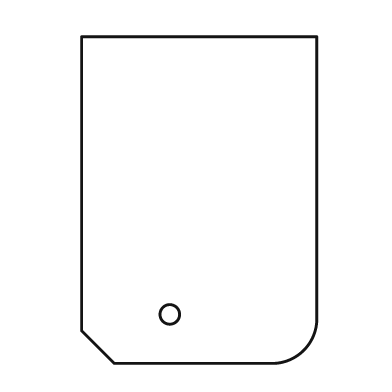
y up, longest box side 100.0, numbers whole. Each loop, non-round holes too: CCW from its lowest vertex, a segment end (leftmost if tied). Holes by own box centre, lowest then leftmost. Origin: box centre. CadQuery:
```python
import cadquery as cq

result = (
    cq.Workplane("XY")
    .moveTo(-26.0, -50.0)
    .lineTo(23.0, -50.0)
    .threePointArc((32.0, -46.0), (36.0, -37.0))
    .lineTo(36.0, 50.0)
    .lineTo(-36.0, 50.0)
    .lineTo(-36.0, -40.0)
    .close()
    .moveTo(-9.0, -35.0)
    .circle(3.0)
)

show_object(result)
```